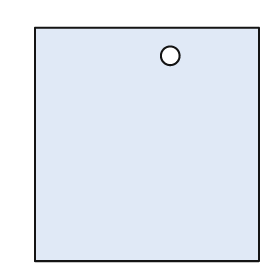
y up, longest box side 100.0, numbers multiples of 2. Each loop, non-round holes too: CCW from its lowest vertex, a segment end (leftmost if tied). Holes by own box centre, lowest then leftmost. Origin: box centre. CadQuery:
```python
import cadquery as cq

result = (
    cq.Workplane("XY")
    .moveTo(-48.0, -50.0)
    .lineTo(48.0, -50.0)
    .lineTo(48.0, 50.0)
    .lineTo(-48.0, 50.0)
    .close()
    .moveTo(10.0, 38.0)
    .circle(4.0)
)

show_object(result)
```